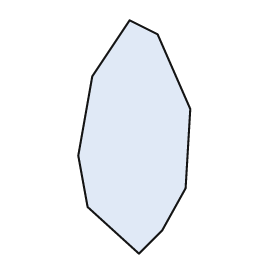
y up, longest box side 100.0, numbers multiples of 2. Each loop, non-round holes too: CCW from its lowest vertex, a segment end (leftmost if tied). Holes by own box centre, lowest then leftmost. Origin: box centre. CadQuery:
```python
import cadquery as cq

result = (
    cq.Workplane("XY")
    .moveTo(2.0, -50.0)
    .lineTo(12.0, -40.0)
    .lineTo(22.0, -22.0)
    .lineTo(24.0, 12.0)
    .lineTo(10.0, 44.0)
    .lineTo(-2.0, 50.0)
    .lineTo(-18.0, 26.0)
    .lineTo(-24.0, -8.0)
    .lineTo(-20.0, -30.0)
    .close()
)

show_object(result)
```